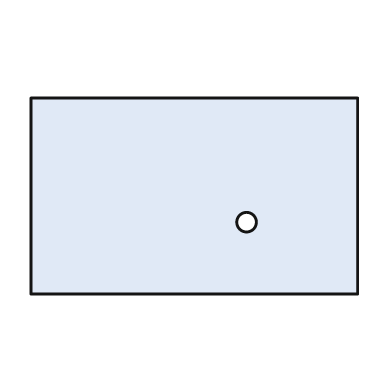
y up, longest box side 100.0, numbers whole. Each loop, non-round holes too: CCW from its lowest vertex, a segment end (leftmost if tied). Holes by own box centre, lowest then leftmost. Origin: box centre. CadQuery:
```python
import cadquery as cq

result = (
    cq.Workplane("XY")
    .moveTo(-50.0, -30.0)
    .lineTo(50.0, -30.0)
    .lineTo(50.0, 30.0)
    .lineTo(-50.0, 30.0)
    .close()
    .moveTo(16.0, -8.0)
    .circle(3.0)
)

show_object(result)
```